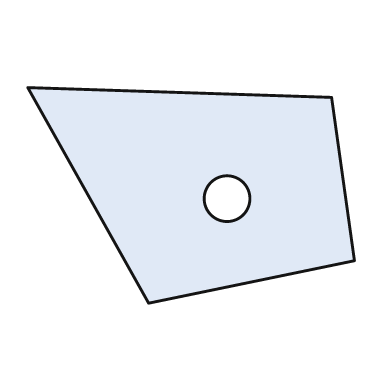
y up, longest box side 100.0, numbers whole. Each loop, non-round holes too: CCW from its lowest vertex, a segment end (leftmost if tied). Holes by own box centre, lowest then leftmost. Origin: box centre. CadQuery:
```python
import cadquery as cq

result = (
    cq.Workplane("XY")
    .moveTo(-13.0, -33.0)
    .lineTo(50.0, -20.0)
    .lineTo(43.0, 30.0)
    .lineTo(-50.0, 33.0)
    .close()
    .moveTo(11.0, -1.0)
    .circle(7.0)
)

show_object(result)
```